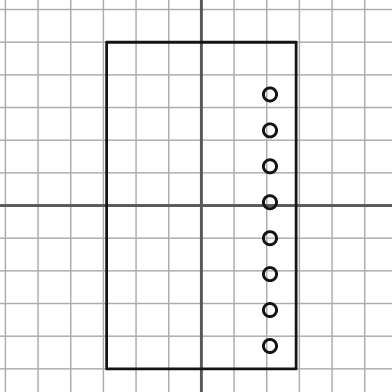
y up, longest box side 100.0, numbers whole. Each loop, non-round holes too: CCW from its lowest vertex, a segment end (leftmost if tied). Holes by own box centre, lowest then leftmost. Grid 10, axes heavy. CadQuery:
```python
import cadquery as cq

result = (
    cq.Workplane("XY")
    .moveTo(-29.0, -50.0)
    .lineTo(29.0, -50.0)
    .lineTo(29.0, 50.0)
    .lineTo(-29.0, 50.0)
    .close()
    .moveTo(21.0, -43.0)
    .circle(2.0)
    .moveTo(21.0, -32.0)
    .circle(2.0)
    .moveTo(21.0, -21.0)
    .circle(2.0)
    .moveTo(21.0, -10.0)
    .circle(2.0)
    .moveTo(21.0, 1.0)
    .circle(2.0)
    .moveTo(21.0, 12.0)
    .circle(2.0)
    .moveTo(21.0, 23.0)
    .circle(2.0)
    .moveTo(21.0, 34.0)
    .circle(2.0)
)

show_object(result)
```